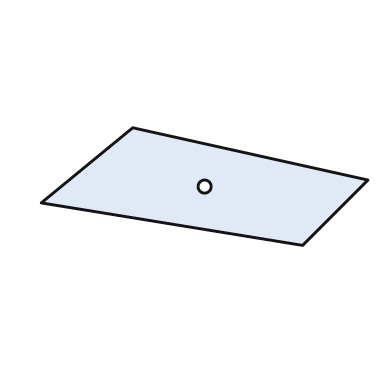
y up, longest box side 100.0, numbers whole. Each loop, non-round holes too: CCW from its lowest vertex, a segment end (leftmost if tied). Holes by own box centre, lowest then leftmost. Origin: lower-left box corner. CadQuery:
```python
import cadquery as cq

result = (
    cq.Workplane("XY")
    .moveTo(80.0, 0.0)
    .lineTo(100.0, 20.0)
    .lineTo(28.0, 36.0)
    .lineTo(0.0, 13.0)
    .close()
    .moveTo(50.0, 18.0)
    .circle(2.0)
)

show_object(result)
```